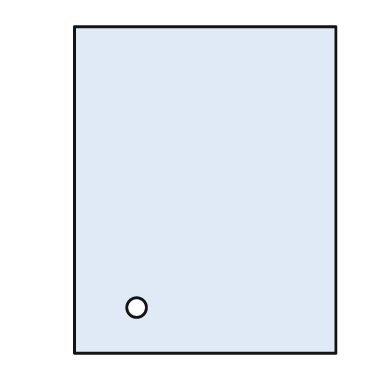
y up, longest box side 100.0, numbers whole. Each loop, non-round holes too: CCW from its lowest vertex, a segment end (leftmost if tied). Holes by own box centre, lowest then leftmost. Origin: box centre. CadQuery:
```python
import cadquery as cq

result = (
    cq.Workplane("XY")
    .moveTo(-40.0, -50.0)
    .lineTo(40.0, -50.0)
    .lineTo(40.0, 50.0)
    .lineTo(-40.0, 50.0)
    .close()
    .moveTo(-21.0, -36.0)
    .circle(3.0)
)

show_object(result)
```